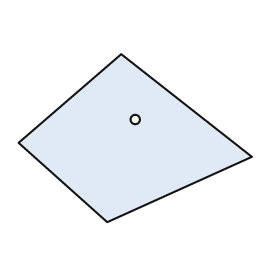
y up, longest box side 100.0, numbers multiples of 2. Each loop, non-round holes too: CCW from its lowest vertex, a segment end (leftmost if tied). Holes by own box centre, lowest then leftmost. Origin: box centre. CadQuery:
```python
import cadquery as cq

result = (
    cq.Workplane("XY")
    .moveTo(-12.0, -36.0)
    .lineTo(50.0, -8.0)
    .lineTo(-6.0, 36.0)
    .lineTo(-50.0, -2.0)
    .close()
    .moveTo(0.0, 8.0)
    .circle(2.0)
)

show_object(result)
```